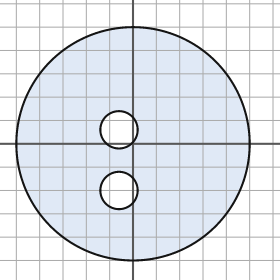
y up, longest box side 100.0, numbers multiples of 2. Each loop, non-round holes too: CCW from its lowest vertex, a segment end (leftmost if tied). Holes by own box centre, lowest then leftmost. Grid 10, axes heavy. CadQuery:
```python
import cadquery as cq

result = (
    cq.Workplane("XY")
    .moveTo(0.0, 0.0)
    .circle(50.0)
    .moveTo(-6.0, -20.0)
    .circle(8.0)
    .moveTo(-6.0, 6.0)
    .circle(8.0)
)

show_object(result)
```